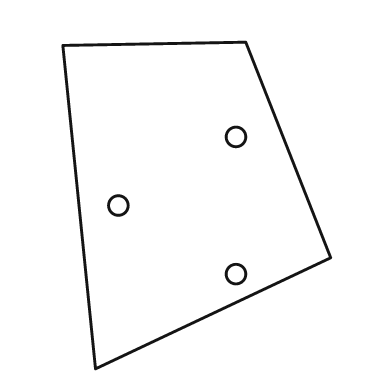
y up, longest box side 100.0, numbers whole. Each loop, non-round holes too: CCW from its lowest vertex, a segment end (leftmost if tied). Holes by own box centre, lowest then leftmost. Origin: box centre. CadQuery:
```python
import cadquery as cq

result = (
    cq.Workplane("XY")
    .moveTo(-31.0, -50.0)
    .lineTo(41.0, -16.0)
    .lineTo(15.0, 50.0)
    .lineTo(-41.0, 49.0)
    .close()
    .moveTo(12.0, -21.0)
    .circle(3.0)
    .moveTo(-24.0, 0.0)
    .circle(3.0)
    .moveTo(12.0, 21.0)
    .circle(3.0)
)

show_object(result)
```